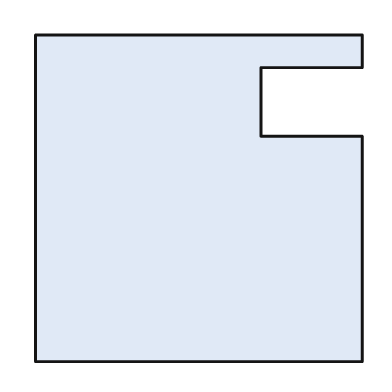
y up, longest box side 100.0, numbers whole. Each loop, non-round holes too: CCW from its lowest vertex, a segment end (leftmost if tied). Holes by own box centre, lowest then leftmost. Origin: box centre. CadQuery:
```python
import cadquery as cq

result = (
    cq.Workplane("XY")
    .moveTo(-50.0, -50.0)
    .lineTo(50.0, -50.0)
    .lineTo(50.0, 19.0)
    .lineTo(19.0, 19.0)
    .lineTo(19.0, 40.0)
    .lineTo(50.0, 40.0)
    .lineTo(50.0, 50.0)
    .lineTo(-50.0, 50.0)
    .close()
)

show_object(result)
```